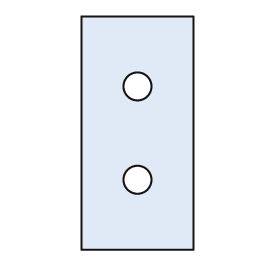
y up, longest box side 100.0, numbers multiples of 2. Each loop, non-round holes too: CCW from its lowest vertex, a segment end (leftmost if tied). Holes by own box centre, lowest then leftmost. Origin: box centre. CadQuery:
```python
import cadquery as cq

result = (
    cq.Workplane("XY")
    .moveTo(-24.0, -50.0)
    .lineTo(24.0, -50.0)
    .lineTo(24.0, 50.0)
    .lineTo(-24.0, 50.0)
    .close()
    .moveTo(0.0, -20.0)
    .circle(6.0)
    .moveTo(0.0, 20.0)
    .circle(6.0)
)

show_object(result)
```